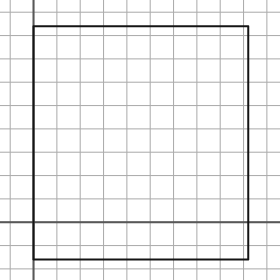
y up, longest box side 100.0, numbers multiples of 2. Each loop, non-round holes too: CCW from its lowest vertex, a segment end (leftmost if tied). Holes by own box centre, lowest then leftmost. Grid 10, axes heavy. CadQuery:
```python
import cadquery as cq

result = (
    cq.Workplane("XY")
    .moveTo(0.0, -16.0)
    .lineTo(92.0, -16.0)
    .lineTo(92.0, 84.0)
    .lineTo(0.0, 84.0)
    .close()
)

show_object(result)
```